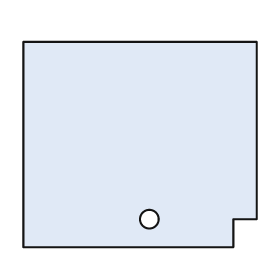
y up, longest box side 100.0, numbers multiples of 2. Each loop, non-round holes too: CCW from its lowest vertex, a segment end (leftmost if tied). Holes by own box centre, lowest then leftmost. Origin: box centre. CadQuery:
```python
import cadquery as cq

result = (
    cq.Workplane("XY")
    .moveTo(-50.0, -44.0)
    .lineTo(40.0, -44.0)
    .lineTo(40.0, -32.0)
    .lineTo(50.0, -32.0)
    .lineTo(50.0, 44.0)
    .lineTo(-50.0, 44.0)
    .close()
    .moveTo(4.0, -32.0)
    .circle(4.0)
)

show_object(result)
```